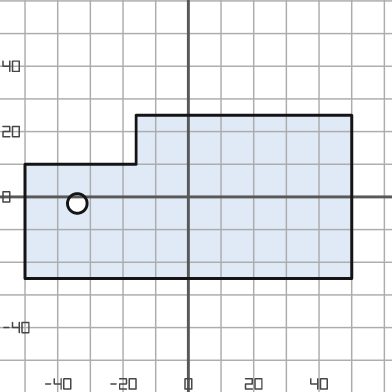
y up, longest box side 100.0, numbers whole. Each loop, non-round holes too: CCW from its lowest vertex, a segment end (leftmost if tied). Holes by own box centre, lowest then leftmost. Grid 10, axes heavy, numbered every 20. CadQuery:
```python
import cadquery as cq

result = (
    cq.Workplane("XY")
    .moveTo(-50.0, -25.0)
    .lineTo(50.0, -25.0)
    .lineTo(50.0, 25.0)
    .lineTo(-16.0, 25.0)
    .lineTo(-16.0, 10.0)
    .lineTo(-50.0, 10.0)
    .close()
    .moveTo(-34.0, -2.0)
    .circle(3.0)
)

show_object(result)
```